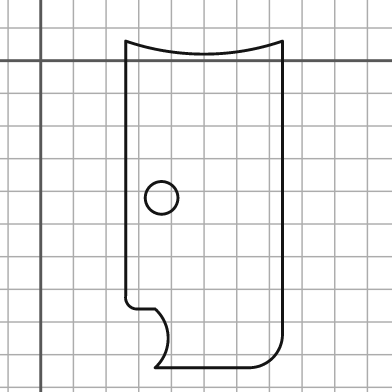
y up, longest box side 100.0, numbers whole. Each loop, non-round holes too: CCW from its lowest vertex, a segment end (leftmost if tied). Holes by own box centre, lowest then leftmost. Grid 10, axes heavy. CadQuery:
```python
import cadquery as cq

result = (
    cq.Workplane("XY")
    .moveTo(35.0, -94.0)
    .lineTo(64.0, -94.0)
    .threePointArc((71.0, -91.0), (74.0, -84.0))
    .lineTo(74.0, 6.0)
    .threePointArc((50.0, 2.0), (26.0, 6.0))
    .lineTo(26.0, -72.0)
    .threePointArc((27.0, -75.0), (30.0, -76.0))
    .lineTo(35.0, -76.0)
    .threePointArc((39.0, -85.0), (35.0, -94.0))
    .close()
    .moveTo(37.0, -42.0)
    .circle(5.0)
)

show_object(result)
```